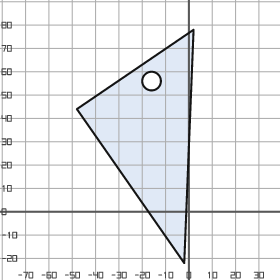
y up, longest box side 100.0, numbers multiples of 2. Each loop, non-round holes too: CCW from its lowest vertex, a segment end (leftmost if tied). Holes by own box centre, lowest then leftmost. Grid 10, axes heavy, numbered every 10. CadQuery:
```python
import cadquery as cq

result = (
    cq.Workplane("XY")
    .moveTo(-2.0, -22.0)
    .lineTo(2.0, 78.0)
    .lineTo(-48.0, 44.0)
    .close()
    .moveTo(-16.0, 56.0)
    .circle(4.0)
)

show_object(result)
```